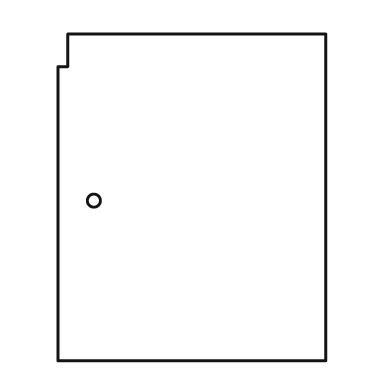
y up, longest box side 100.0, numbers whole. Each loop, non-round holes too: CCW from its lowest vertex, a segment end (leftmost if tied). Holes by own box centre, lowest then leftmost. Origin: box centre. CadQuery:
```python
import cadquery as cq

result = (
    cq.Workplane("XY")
    .moveTo(-41.0, -50.0)
    .lineTo(41.0, -50.0)
    .lineTo(41.0, 50.0)
    .lineTo(-38.0, 50.0)
    .lineTo(-38.0, 40.0)
    .lineTo(-41.0, 40.0)
    .close()
    .moveTo(-30.0, -1.0)
    .circle(2.0)
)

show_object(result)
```